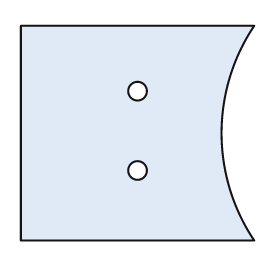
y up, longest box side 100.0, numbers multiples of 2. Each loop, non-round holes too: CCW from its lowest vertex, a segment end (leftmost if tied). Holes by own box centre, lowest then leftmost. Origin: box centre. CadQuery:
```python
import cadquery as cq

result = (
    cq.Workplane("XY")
    .moveTo(-50.0, -46.0)
    .lineTo(50.0, -46.0)
    .threePointArc((36.0, 0.0), (50.0, 46.0))
    .lineTo(-50.0, 46.0)
    .close()
    .moveTo(0.0, -16.0)
    .circle(4.0)
    .moveTo(0.0, 18.0)
    .circle(4.0)
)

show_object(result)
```